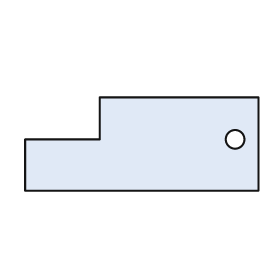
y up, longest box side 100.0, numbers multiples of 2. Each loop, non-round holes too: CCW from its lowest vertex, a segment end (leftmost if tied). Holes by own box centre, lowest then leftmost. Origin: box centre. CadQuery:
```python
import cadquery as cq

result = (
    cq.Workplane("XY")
    .moveTo(-50.0, -20.0)
    .lineTo(50.0, -20.0)
    .lineTo(50.0, 20.0)
    .lineTo(-18.0, 20.0)
    .lineTo(-18.0, 2.0)
    .lineTo(-50.0, 2.0)
    .close()
    .moveTo(40.0, 2.0)
    .circle(4.0)
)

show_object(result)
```